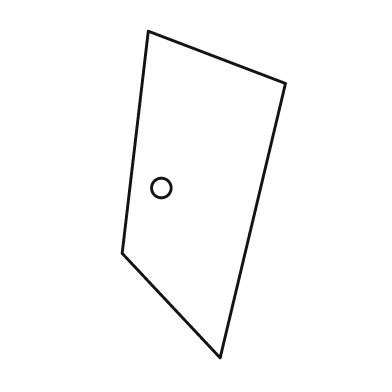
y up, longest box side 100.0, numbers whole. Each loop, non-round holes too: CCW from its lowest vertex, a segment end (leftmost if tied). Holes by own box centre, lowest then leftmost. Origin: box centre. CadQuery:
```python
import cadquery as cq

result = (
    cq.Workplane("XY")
    .moveTo(5.0, -50.0)
    .lineTo(25.0, 34.0)
    .lineTo(-17.0, 50.0)
    .lineTo(-25.0, -18.0)
    .close()
    .moveTo(-13.0, 2.0)
    .circle(3.0)
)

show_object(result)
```